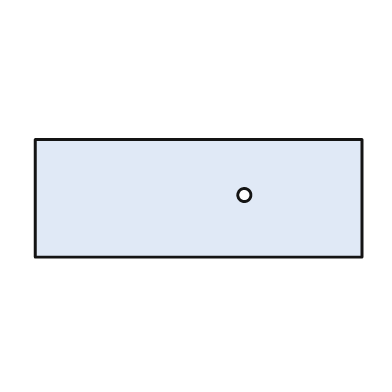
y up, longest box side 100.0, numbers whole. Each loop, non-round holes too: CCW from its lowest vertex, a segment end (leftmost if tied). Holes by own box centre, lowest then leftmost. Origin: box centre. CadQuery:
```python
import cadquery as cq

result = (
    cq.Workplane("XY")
    .moveTo(-50.0, -18.0)
    .lineTo(50.0, -18.0)
    .lineTo(50.0, 18.0)
    .lineTo(-50.0, 18.0)
    .close()
    .moveTo(14.0, 1.0)
    .circle(2.0)
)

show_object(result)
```